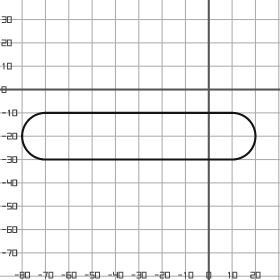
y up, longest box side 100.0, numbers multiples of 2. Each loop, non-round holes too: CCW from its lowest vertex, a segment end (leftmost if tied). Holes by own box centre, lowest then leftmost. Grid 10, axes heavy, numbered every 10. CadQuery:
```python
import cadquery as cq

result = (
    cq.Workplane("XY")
    .moveTo(-70.0, -30.0)
    .lineTo(10.0, -30.0)
    .threePointArc((20.0, -20.0), (10.0, -10.0))
    .lineTo(-70.0, -10.0)
    .threePointArc((-80.0, -20.0), (-70.0, -30.0))
    .close()
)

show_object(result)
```